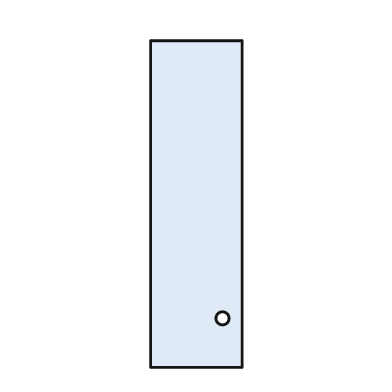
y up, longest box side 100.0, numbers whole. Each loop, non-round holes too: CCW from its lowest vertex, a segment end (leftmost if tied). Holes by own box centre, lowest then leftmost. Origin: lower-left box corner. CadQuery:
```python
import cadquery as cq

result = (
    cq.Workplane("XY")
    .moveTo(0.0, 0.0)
    .lineTo(28.0, 0.0)
    .lineTo(28.0, 100.0)
    .lineTo(0.0, 100.0)
    .close()
    .moveTo(22.0, 15.0)
    .circle(2.0)
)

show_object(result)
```